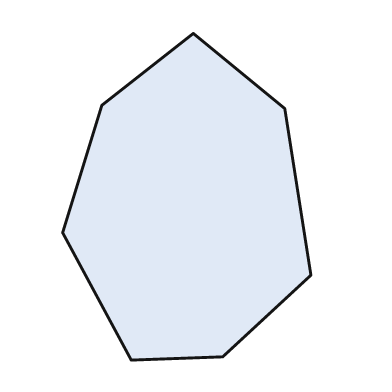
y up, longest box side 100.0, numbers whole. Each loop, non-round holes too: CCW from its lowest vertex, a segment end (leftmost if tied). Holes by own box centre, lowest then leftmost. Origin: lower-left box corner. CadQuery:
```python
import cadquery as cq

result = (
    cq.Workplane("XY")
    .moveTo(21.0, 0.0)
    .lineTo(49.0, 1.0)
    .lineTo(76.0, 26.0)
    .lineTo(68.0, 77.0)
    .lineTo(40.0, 100.0)
    .lineTo(12.0, 78.0)
    .lineTo(0.0, 39.0)
    .close()
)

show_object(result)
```